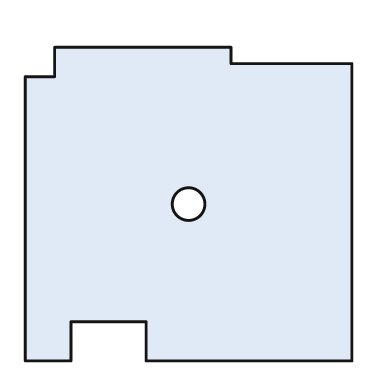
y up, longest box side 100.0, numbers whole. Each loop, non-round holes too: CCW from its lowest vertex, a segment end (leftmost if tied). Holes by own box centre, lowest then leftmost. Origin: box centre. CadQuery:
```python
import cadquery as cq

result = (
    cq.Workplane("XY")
    .moveTo(-50.0, -48.0)
    .lineTo(-36.0, -48.0)
    .lineTo(-36.0, -36.0)
    .lineTo(-13.0, -36.0)
    .lineTo(-13.0, -48.0)
    .lineTo(50.0, -48.0)
    .lineTo(50.0, 43.0)
    .lineTo(13.0, 43.0)
    .lineTo(13.0, 48.0)
    .lineTo(-41.0, 48.0)
    .lineTo(-41.0, 39.0)
    .lineTo(-50.0, 39.0)
    .close()
    .moveTo(0.0, 0.0)
    .circle(5.0)
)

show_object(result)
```